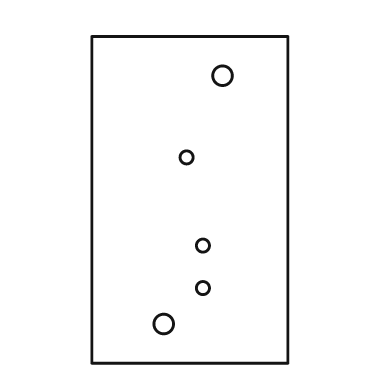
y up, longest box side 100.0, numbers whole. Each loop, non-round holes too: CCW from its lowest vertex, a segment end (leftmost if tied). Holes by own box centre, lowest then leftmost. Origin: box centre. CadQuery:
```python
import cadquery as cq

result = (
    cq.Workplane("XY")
    .moveTo(-30.0, -50.0)
    .lineTo(30.0, -50.0)
    .lineTo(30.0, 50.0)
    .lineTo(-30.0, 50.0)
    .close()
    .moveTo(-8.0, -38.0)
    .circle(3.0)
    .moveTo(4.0, -27.0)
    .circle(2.0)
    .moveTo(4.0, -14.0)
    .circle(2.0)
    .moveTo(-1.0, 13.0)
    .circle(2.0)
    .moveTo(10.0, 38.0)
    .circle(3.0)
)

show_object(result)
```